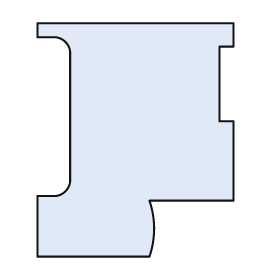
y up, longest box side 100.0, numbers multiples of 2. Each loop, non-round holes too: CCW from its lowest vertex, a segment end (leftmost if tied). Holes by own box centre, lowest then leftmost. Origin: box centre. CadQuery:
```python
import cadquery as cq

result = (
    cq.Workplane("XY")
    .moveTo(-42.0, -50.0)
    .lineTo(6.0, -50.0)
    .threePointArc((8.0, -38.0), (6.0, -26.0))
    .lineTo(42.0, -26.0)
    .lineTo(42.0, 8.0)
    .lineTo(36.0, 8.0)
    .lineTo(36.0, 40.0)
    .lineTo(42.0, 40.0)
    .lineTo(42.0, 50.0)
    .lineTo(-42.0, 50.0)
    .lineTo(-42.0, 44.0)
    .lineTo(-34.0, 44.0)
    .threePointArc((-30.0, 42.0), (-28.0, 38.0))
    .lineTo(-28.0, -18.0)
    .threePointArc((-30.0, -22.0), (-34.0, -24.0))
    .lineTo(-42.0, -24.0)
    .close()
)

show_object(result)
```